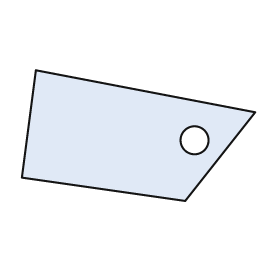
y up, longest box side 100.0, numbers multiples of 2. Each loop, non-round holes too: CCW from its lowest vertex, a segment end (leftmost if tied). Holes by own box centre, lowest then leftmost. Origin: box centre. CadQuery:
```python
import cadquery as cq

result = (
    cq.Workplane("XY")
    .moveTo(20.0, -28.0)
    .lineTo(50.0, 10.0)
    .lineTo(-44.0, 28.0)
    .lineTo(-50.0, -18.0)
    .close()
    .moveTo(24.0, -2.0)
    .circle(6.0)
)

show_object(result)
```